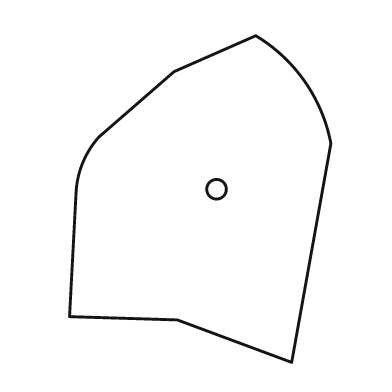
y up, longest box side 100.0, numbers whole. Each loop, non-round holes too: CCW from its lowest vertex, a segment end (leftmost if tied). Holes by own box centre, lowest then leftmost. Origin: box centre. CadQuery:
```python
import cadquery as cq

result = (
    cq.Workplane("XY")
    .moveTo(28.0, -50.0)
    .lineTo(40.0, 17.0)
    .threePointArc((32.0, 36.0), (17.0, 50.0))
    .lineTo(-8.0, 39.0)
    .lineTo(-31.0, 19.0)
    .threePointArc((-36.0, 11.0), (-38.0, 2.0))
    .lineTo(-40.0, -36.0)
    .lineTo(-7.0, -37.0)
    .close()
    .moveTo(5.0, 3.0)
    .circle(3.0)
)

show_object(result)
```